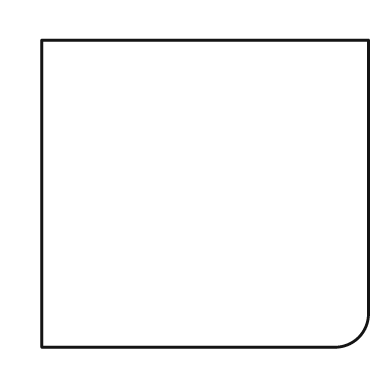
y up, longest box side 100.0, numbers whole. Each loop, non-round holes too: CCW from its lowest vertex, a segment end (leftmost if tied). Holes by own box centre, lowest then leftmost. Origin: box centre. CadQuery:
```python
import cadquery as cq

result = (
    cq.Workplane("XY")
    .moveTo(-50.0, -47.0)
    .lineTo(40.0, -47.0)
    .threePointArc((47.0, -44.0), (50.0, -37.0))
    .lineTo(50.0, 47.0)
    .lineTo(-50.0, 47.0)
    .close()
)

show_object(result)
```